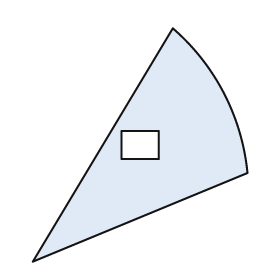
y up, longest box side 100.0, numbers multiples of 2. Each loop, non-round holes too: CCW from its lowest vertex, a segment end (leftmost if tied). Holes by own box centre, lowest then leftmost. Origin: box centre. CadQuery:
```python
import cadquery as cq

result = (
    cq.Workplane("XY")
    .moveTo(-46.0, -50.0)
    .lineTo(46.0, -12.0)
    .threePointArc((36.0, 22.0), (14.0, 50.0))
    .close()
    .moveTo(-8.0, -6.0)
    .lineTo(8.0, -6.0)
    .lineTo(8.0, 6.0)
    .lineTo(-8.0, 6.0)
    .close()
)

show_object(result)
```